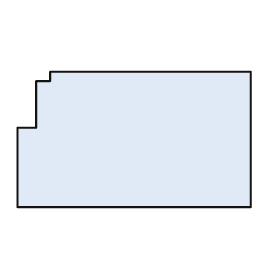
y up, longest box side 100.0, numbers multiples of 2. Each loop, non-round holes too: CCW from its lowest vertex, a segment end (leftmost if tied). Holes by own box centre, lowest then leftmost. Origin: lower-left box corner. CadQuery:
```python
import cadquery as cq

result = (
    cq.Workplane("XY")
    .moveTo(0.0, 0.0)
    .lineTo(100.0, 0.0)
    .lineTo(100.0, 58.0)
    .lineTo(14.0, 58.0)
    .lineTo(14.0, 54.0)
    .lineTo(8.0, 54.0)
    .lineTo(8.0, 34.0)
    .lineTo(0.0, 34.0)
    .close()
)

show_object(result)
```